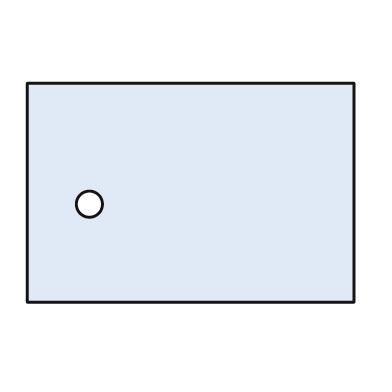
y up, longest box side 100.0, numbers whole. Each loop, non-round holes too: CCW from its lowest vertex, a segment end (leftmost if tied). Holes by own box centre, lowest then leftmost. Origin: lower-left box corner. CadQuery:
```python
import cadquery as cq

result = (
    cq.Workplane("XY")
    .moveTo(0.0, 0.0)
    .lineTo(100.0, 0.0)
    .lineTo(100.0, 67.0)
    .lineTo(0.0, 67.0)
    .close()
    .moveTo(19.0, 30.0)
    .circle(4.0)
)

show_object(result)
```